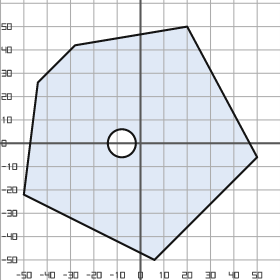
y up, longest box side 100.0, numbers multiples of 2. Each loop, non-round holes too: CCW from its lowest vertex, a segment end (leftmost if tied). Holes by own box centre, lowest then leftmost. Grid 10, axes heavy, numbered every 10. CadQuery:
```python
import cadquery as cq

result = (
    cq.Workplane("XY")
    .moveTo(6.0, -50.0)
    .lineTo(50.0, -6.0)
    .lineTo(20.0, 50.0)
    .lineTo(-28.0, 42.0)
    .lineTo(-44.0, 26.0)
    .lineTo(-50.0, -22.0)
    .close()
    .moveTo(-8.0, 0.0)
    .circle(6.0)
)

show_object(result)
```